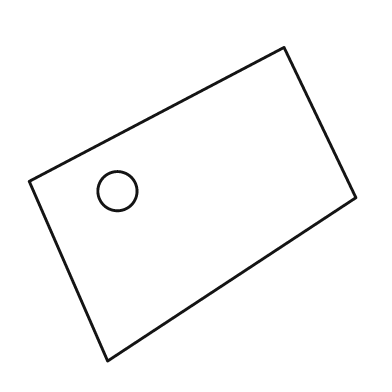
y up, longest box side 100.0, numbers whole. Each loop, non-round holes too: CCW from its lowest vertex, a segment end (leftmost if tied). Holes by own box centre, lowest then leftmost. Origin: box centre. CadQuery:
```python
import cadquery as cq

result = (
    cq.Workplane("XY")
    .moveTo(-26.0, -48.0)
    .lineTo(50.0, 2.0)
    .lineTo(28.0, 48.0)
    .lineTo(-50.0, 7.0)
    .close()
    .moveTo(-23.0, 4.0)
    .circle(6.0)
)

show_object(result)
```